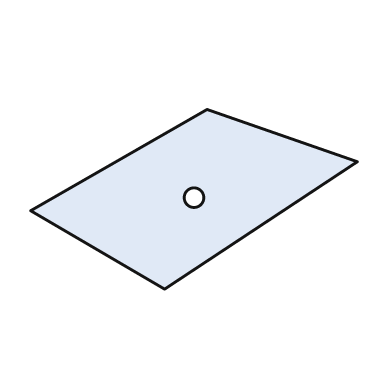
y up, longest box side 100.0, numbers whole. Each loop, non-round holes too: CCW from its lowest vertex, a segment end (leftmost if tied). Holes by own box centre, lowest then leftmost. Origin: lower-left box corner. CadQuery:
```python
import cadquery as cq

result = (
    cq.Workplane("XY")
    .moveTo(41.0, 0.0)
    .lineTo(100.0, 39.0)
    .lineTo(54.0, 55.0)
    .lineTo(0.0, 24.0)
    .close()
    .moveTo(50.0, 28.0)
    .circle(3.0)
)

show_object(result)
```